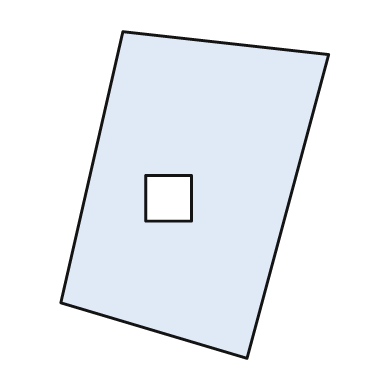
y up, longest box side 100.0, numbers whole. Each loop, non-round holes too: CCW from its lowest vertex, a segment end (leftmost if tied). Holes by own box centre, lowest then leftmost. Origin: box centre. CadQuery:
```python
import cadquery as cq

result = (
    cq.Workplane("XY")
    .moveTo(16.0, -50.0)
    .lineTo(41.0, 43.0)
    .lineTo(-22.0, 50.0)
    .lineTo(-41.0, -33.0)
    .close()
    .moveTo(-15.0, -8.0)
    .lineTo(-1.0, -8.0)
    .lineTo(-1.0, 6.0)
    .lineTo(-15.0, 6.0)
    .close()
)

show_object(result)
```